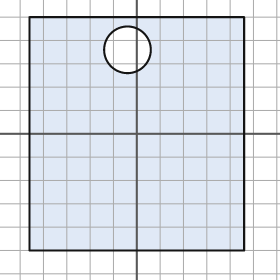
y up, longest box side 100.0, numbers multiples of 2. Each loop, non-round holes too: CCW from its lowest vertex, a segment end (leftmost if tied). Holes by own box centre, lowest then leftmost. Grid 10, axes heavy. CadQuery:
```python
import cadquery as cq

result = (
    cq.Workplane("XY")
    .moveTo(-46.0, -50.0)
    .lineTo(46.0, -50.0)
    .lineTo(46.0, 50.0)
    .lineTo(-46.0, 50.0)
    .close()
    .moveTo(-4.0, 36.0)
    .circle(10.0)
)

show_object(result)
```